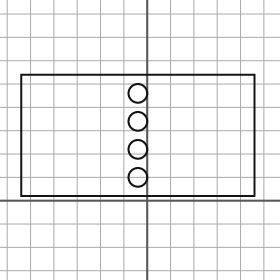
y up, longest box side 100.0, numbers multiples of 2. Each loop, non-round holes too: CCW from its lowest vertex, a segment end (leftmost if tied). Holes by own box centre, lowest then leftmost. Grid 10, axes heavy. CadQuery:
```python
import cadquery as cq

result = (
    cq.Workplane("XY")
    .moveTo(-54.0, 2.0)
    .lineTo(46.0, 2.0)
    .lineTo(46.0, 54.0)
    .lineTo(-54.0, 54.0)
    .close()
    .moveTo(-4.0, 10.0)
    .circle(4.0)
    .moveTo(-4.0, 22.0)
    .circle(4.0)
    .moveTo(-4.0, 34.0)
    .circle(4.0)
    .moveTo(-4.0, 46.0)
    .circle(4.0)
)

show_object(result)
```